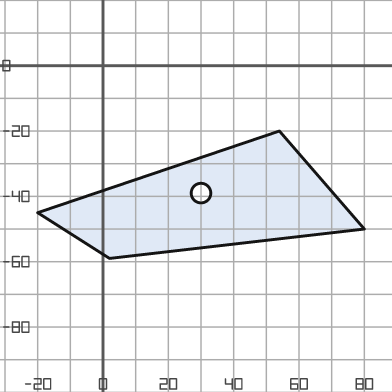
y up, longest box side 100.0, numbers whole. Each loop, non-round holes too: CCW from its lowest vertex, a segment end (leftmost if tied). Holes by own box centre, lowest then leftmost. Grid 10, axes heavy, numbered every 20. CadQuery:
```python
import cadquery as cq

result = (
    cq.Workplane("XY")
    .moveTo(2.0, -59.0)
    .lineTo(80.0, -50.0)
    .lineTo(54.0, -20.0)
    .lineTo(-20.0, -45.0)
    .close()
    .moveTo(30.0, -39.0)
    .circle(3.0)
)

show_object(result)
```